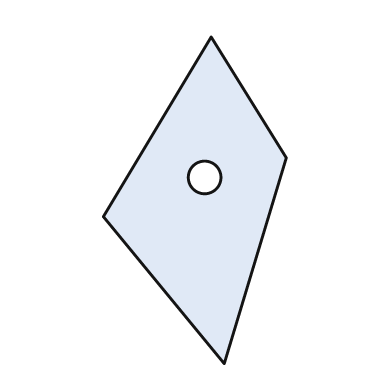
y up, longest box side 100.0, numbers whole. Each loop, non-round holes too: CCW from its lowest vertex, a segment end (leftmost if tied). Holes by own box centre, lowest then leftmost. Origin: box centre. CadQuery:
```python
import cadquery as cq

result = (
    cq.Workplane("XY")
    .moveTo(9.0, -50.0)
    .lineTo(28.0, 13.0)
    .lineTo(5.0, 50.0)
    .lineTo(-28.0, -5.0)
    .close()
    .moveTo(3.0, 7.0)
    .circle(5.0)
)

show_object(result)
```